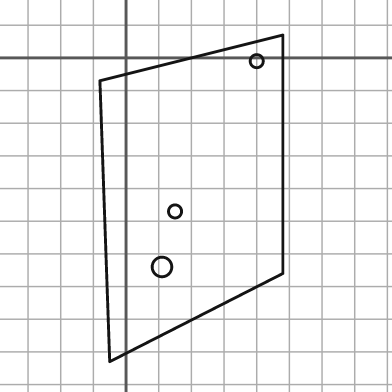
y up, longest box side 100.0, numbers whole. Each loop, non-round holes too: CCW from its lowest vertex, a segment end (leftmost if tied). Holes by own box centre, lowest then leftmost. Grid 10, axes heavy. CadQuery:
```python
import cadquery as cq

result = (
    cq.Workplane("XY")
    .moveTo(-5.0, -93.0)
    .lineTo(48.0, -66.0)
    .lineTo(48.0, 7.0)
    .lineTo(-8.0, -7.0)
    .close()
    .moveTo(11.0, -64.0)
    .circle(3.0)
    .moveTo(15.0, -47.0)
    .circle(2.0)
    .moveTo(40.0, -1.0)
    .circle(2.0)
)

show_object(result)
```